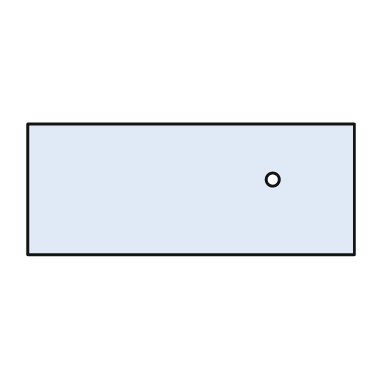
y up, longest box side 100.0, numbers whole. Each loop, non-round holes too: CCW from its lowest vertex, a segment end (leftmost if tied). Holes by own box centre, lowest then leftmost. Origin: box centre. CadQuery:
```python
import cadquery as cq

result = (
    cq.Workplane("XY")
    .moveTo(-50.0, -20.0)
    .lineTo(50.0, -20.0)
    .lineTo(50.0, 20.0)
    .lineTo(-50.0, 20.0)
    .close()
    .moveTo(25.0, 3.0)
    .circle(2.0)
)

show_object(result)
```